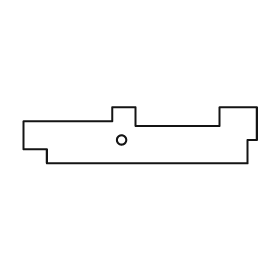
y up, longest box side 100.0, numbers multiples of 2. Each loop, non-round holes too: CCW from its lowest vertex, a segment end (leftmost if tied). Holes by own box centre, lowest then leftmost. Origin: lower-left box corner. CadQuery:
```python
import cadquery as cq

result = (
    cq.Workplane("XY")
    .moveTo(10.0, 0.0)
    .lineTo(96.0, 0.0)
    .lineTo(96.0, 10.0)
    .lineTo(100.0, 10.0)
    .lineTo(100.0, 24.0)
    .lineTo(84.0, 24.0)
    .lineTo(84.0, 16.0)
    .lineTo(48.0, 16.0)
    .lineTo(48.0, 24.0)
    .lineTo(38.0, 24.0)
    .lineTo(38.0, 18.0)
    .lineTo(0.0, 18.0)
    .lineTo(0.0, 6.0)
    .lineTo(10.0, 6.0)
    .close()
    .moveTo(42.0, 10.0)
    .circle(2.0)
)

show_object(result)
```